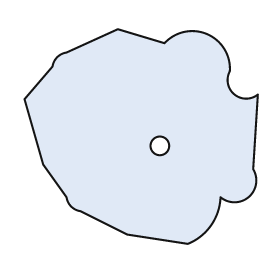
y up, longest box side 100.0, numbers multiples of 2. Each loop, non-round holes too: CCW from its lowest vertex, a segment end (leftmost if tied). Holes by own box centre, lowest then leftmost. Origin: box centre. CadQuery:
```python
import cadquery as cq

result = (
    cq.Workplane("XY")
    .moveTo(20.0, -46.0)
    .threePointArc((30.0, -38.0), (34.0, -26.0))
    .threePointArc((46.0, -26.0), (48.0, -14.0))
    .lineTo(50.0, 18.0)
    .threePointArc((40.0, 18.0), (38.0, 28.0))
    .threePointArc((28.0, 44.0), (10.0, 40.0))
    .lineTo(-10.0, 46.0)
    .lineTo(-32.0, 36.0)
    .threePointArc((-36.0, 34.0), (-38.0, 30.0))
    .lineTo(-50.0, 16.0)
    .lineTo(-42.0, -12.0)
    .lineTo(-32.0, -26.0)
    .threePointArc((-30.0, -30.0), (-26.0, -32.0))
    .lineTo(-6.0, -42.0)
    .close()
    .moveTo(8.0, -4.0)
    .circle(4.0)
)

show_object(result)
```